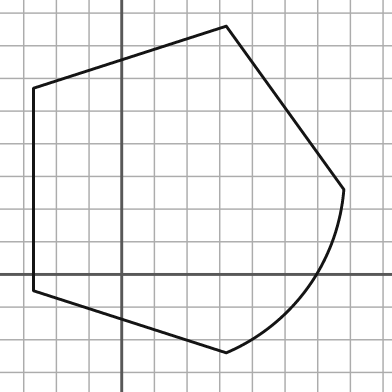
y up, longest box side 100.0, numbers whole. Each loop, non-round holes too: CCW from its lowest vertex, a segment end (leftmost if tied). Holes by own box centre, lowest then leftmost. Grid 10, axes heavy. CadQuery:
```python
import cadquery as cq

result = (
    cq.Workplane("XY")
    .moveTo(32.0, -24.0)
    .threePointArc((57.0, -4.0), (68.0, 26.0))
    .lineTo(32.0, 76.0)
    .lineTo(-27.0, 57.0)
    .lineTo(-27.0, -5.0)
    .close()
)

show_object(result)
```